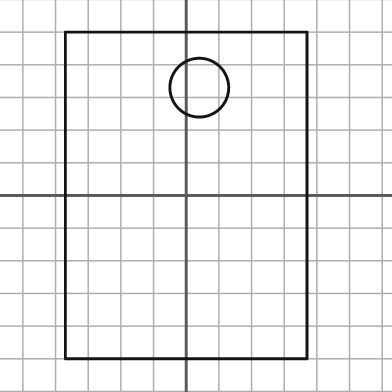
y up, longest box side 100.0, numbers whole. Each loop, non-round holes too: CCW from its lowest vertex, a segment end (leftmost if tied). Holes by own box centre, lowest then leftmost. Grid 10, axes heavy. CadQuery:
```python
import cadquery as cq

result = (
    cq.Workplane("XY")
    .moveTo(-37.0, -50.0)
    .lineTo(37.0, -50.0)
    .lineTo(37.0, 50.0)
    .lineTo(-37.0, 50.0)
    .close()
    .moveTo(4.0, 33.0)
    .circle(9.0)
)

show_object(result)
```